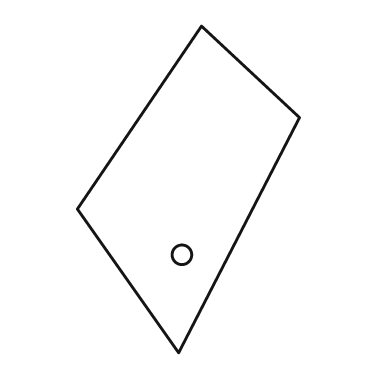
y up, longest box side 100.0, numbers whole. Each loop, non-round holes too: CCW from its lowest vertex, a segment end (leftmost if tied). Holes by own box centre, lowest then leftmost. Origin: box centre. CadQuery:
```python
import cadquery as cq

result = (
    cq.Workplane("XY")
    .moveTo(-3.0, -50.0)
    .lineTo(34.0, 22.0)
    .lineTo(4.0, 50.0)
    .lineTo(-34.0, -6.0)
    .close()
    .moveTo(-2.0, -20.0)
    .circle(3.0)
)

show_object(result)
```